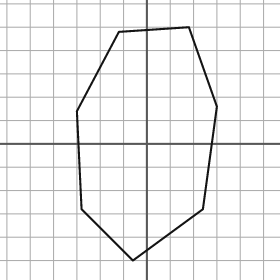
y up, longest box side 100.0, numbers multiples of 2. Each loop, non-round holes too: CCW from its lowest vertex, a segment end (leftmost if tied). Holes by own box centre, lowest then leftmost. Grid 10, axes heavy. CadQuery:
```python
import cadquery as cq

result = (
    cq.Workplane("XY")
    .moveTo(-6.0, -50.0)
    .lineTo(24.0, -28.0)
    .lineTo(30.0, 16.0)
    .lineTo(18.0, 50.0)
    .lineTo(-12.0, 48.0)
    .lineTo(-30.0, 14.0)
    .lineTo(-28.0, -28.0)
    .close()
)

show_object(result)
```